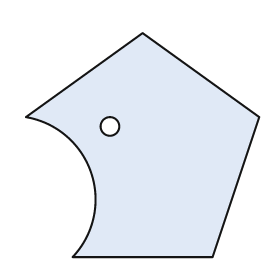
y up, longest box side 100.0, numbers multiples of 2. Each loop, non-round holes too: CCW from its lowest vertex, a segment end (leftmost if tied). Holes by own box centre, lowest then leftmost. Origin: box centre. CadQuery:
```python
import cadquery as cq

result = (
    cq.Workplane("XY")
    .moveTo(-30.0, -48.0)
    .lineTo(30.0, -48.0)
    .lineTo(50.0, 12.0)
    .lineTo(0.0, 48.0)
    .lineTo(-50.0, 12.0)
    .threePointArc((-22.0, -12.0), (-30.0, -48.0))
    .close()
    .moveTo(-14.0, 8.0)
    .circle(4.0)
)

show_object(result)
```